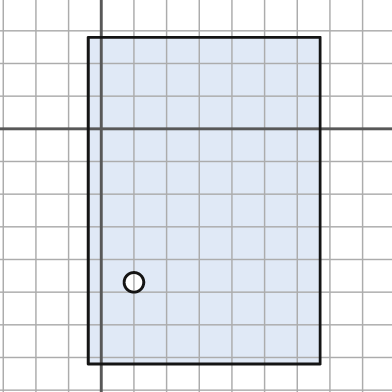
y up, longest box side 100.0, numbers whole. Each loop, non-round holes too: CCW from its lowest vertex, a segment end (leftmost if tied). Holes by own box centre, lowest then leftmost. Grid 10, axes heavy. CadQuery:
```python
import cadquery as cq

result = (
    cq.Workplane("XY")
    .moveTo(-4.0, -72.0)
    .lineTo(67.0, -72.0)
    .lineTo(67.0, 28.0)
    .lineTo(-4.0, 28.0)
    .close()
    .moveTo(10.0, -47.0)
    .circle(3.0)
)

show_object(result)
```